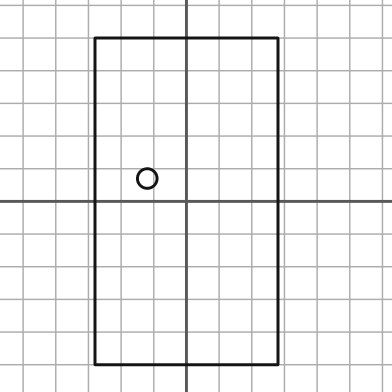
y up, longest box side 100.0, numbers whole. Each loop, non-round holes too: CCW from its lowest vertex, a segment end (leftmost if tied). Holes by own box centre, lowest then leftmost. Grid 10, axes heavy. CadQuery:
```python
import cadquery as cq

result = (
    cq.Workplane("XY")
    .moveTo(-28.0, -50.0)
    .lineTo(28.0, -50.0)
    .lineTo(28.0, 50.0)
    .lineTo(-28.0, 50.0)
    .close()
    .moveTo(-12.0, 7.0)
    .circle(3.0)
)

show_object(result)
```